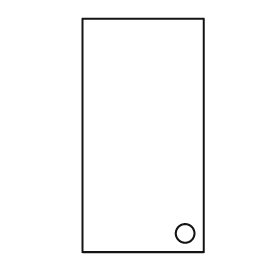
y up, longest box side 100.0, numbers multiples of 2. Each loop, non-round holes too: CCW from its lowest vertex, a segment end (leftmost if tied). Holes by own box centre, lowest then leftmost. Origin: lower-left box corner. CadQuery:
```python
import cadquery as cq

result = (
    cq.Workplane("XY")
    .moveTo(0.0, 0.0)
    .lineTo(52.0, 0.0)
    .lineTo(52.0, 100.0)
    .lineTo(0.0, 100.0)
    .close()
    .moveTo(44.0, 8.0)
    .circle(4.0)
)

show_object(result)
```